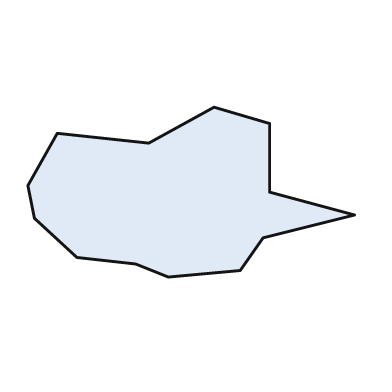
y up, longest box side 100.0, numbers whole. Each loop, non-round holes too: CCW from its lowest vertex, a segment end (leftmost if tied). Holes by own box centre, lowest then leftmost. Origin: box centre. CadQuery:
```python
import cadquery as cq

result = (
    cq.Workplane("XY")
    .moveTo(-7.0, -26.0)
    .lineTo(15.0, -24.0)
    .lineTo(22.0, -14.0)
    .lineTo(50.0, -7.0)
    .lineTo(24.0, 0.0)
    .lineTo(24.0, 21.0)
    .lineTo(7.0, 26.0)
    .lineTo(-13.0, 15.0)
    .lineTo(-41.0, 18.0)
    .lineTo(-50.0, 2.0)
    .lineTo(-48.0, -8.0)
    .lineTo(-35.0, -20.0)
    .lineTo(-17.0, -22.0)
    .close()
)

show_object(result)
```